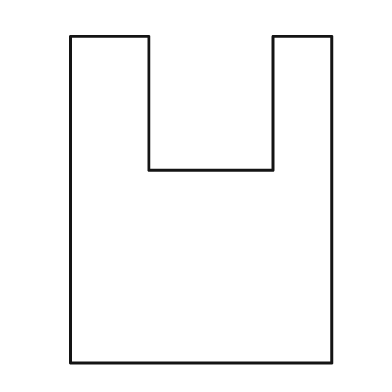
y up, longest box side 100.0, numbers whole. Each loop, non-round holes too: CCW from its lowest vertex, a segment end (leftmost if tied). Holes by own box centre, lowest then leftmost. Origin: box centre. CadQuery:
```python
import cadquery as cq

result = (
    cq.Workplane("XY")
    .moveTo(-40.0, -50.0)
    .lineTo(40.0, -50.0)
    .lineTo(40.0, 50.0)
    .lineTo(22.0, 50.0)
    .lineTo(22.0, 9.0)
    .lineTo(-16.0, 9.0)
    .lineTo(-16.0, 50.0)
    .lineTo(-40.0, 50.0)
    .close()
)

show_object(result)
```